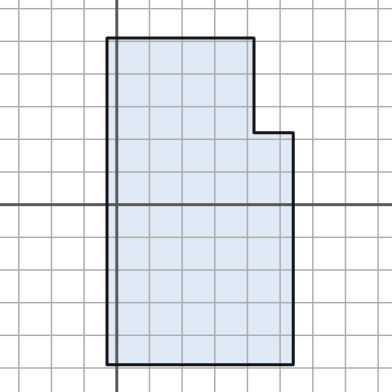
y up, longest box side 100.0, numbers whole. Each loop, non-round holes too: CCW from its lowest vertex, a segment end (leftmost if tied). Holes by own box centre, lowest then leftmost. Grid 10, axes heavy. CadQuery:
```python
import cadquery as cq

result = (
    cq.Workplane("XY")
    .moveTo(-3.0, -49.0)
    .lineTo(54.0, -49.0)
    .lineTo(54.0, 22.0)
    .lineTo(42.0, 22.0)
    .lineTo(42.0, 51.0)
    .lineTo(-3.0, 51.0)
    .close()
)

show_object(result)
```